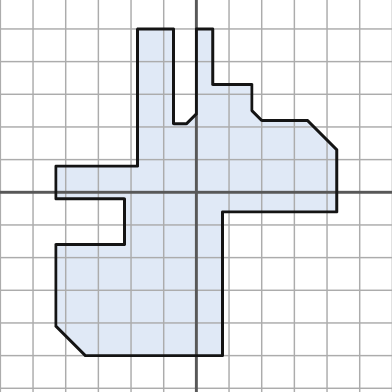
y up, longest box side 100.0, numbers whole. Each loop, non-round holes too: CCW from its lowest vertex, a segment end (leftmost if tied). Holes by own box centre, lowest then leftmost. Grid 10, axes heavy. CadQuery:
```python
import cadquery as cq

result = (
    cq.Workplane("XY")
    .moveTo(-34.0, -50.0)
    .lineTo(8.0, -50.0)
    .lineTo(8.0, -6.0)
    .lineTo(43.0, -6.0)
    .lineTo(43.0, 13.0)
    .lineTo(34.0, 22.0)
    .lineTo(20.0, 22.0)
    .lineTo(17.0, 25.0)
    .lineTo(17.0, 33.0)
    .lineTo(5.0, 33.0)
    .lineTo(5.0, 50.0)
    .lineTo(0.0, 50.0)
    .lineTo(0.0, 24.0)
    .lineTo(-3.0, 21.0)
    .lineTo(-7.0, 21.0)
    .lineTo(-7.0, 50.0)
    .lineTo(-18.0, 50.0)
    .lineTo(-18.0, 8.0)
    .lineTo(-43.0, 8.0)
    .lineTo(-43.0, -2.0)
    .lineTo(-22.0, -2.0)
    .lineTo(-22.0, -16.0)
    .lineTo(-43.0, -16.0)
    .lineTo(-43.0, -41.0)
    .close()
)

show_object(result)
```